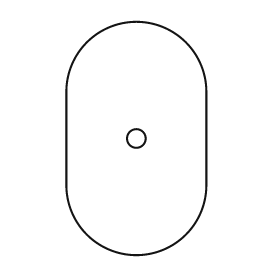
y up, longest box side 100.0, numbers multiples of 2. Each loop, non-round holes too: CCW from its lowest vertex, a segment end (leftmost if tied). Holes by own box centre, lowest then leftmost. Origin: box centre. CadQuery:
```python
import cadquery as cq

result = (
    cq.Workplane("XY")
    .moveTo(-30.0, -20.0)
    .threePointArc((0.0, -50.0), (30.0, -20.0))
    .lineTo(30.0, 20.0)
    .threePointArc((0.0, 50.0), (-30.0, 20.0))
    .close()
    .moveTo(0.0, 0.0)
    .circle(4.0)
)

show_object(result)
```